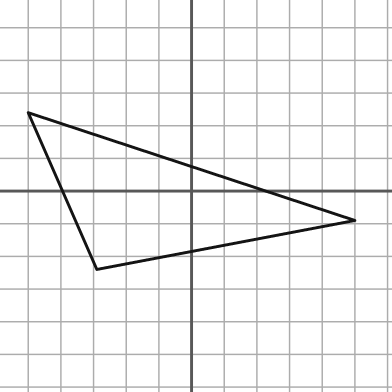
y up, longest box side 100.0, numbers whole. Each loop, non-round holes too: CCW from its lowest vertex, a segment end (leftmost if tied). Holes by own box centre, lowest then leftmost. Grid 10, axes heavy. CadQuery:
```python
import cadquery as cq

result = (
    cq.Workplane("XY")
    .moveTo(-29.0, -24.0)
    .lineTo(50.0, -9.0)
    .lineTo(-50.0, 24.0)
    .close()
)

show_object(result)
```